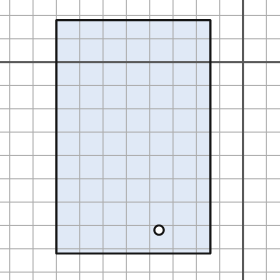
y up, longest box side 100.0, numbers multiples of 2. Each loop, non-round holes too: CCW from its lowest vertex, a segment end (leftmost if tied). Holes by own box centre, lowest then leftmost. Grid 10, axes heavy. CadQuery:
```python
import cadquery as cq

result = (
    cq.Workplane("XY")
    .moveTo(-80.0, -82.0)
    .lineTo(-14.0, -82.0)
    .lineTo(-14.0, 18.0)
    .lineTo(-80.0, 18.0)
    .close()
    .moveTo(-36.0, -72.0)
    .circle(2.0)
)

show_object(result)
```